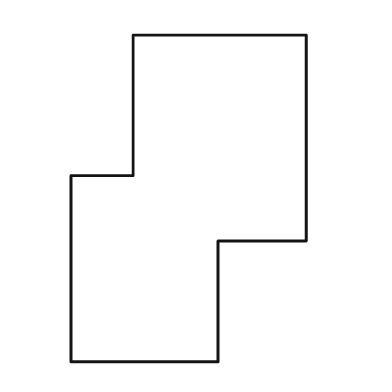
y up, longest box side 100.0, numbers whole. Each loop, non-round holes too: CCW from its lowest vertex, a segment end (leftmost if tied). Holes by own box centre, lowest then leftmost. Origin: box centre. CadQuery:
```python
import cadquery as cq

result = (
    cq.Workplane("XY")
    .moveTo(-36.0, -50.0)
    .lineTo(9.0, -50.0)
    .lineTo(9.0, -13.0)
    .lineTo(36.0, -13.0)
    .lineTo(36.0, 50.0)
    .lineTo(-17.0, 50.0)
    .lineTo(-17.0, 7.0)
    .lineTo(-36.0, 7.0)
    .close()
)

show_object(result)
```